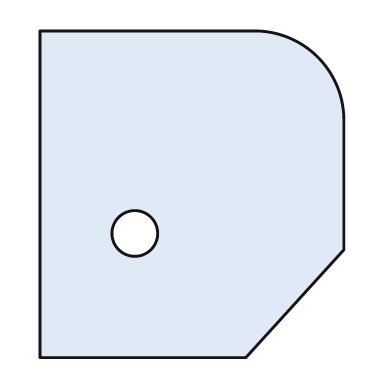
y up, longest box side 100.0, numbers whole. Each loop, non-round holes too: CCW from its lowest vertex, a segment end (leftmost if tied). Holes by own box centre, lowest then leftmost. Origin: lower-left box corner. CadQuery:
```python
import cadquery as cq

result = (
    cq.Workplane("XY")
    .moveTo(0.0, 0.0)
    .lineTo(63.0, 0.0)
    .lineTo(93.0, 33.0)
    .lineTo(93.0, 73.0)
    .threePointArc((85.0, 92.0), (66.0, 100.0))
    .lineTo(0.0, 100.0)
    .close()
    .moveTo(29.0, 38.0)
    .circle(7.0)
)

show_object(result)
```